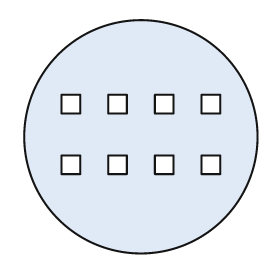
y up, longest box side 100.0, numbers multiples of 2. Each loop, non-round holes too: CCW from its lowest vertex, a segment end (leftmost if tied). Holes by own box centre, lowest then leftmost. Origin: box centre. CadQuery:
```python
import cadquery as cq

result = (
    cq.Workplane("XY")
    .moveTo(0.0, 0.0)
    .circle(50.0)
    .moveTo(-34.0, -16.0)
    .lineTo(-26.0, -16.0)
    .lineTo(-26.0, -8.0)
    .lineTo(-34.0, -8.0)
    .close()
    .moveTo(-14.0, -16.0)
    .lineTo(-6.0, -16.0)
    .lineTo(-6.0, -8.0)
    .lineTo(-14.0, -8.0)
    .close()
    .moveTo(6.0, -16.0)
    .lineTo(14.0, -16.0)
    .lineTo(14.0, -8.0)
    .lineTo(6.0, -8.0)
    .close()
    .moveTo(26.0, -16.0)
    .lineTo(34.0, -16.0)
    .lineTo(34.0, -8.0)
    .lineTo(26.0, -8.0)
    .close()
    .moveTo(-34.0, 10.0)
    .lineTo(-26.0, 10.0)
    .lineTo(-26.0, 18.0)
    .lineTo(-34.0, 18.0)
    .close()
    .moveTo(-14.0, 10.0)
    .lineTo(-6.0, 10.0)
    .lineTo(-6.0, 18.0)
    .lineTo(-14.0, 18.0)
    .close()
    .moveTo(6.0, 10.0)
    .lineTo(14.0, 10.0)
    .lineTo(14.0, 18.0)
    .lineTo(6.0, 18.0)
    .close()
    .moveTo(26.0, 10.0)
    .lineTo(34.0, 10.0)
    .lineTo(34.0, 18.0)
    .lineTo(26.0, 18.0)
    .close()
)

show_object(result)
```